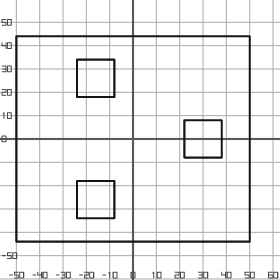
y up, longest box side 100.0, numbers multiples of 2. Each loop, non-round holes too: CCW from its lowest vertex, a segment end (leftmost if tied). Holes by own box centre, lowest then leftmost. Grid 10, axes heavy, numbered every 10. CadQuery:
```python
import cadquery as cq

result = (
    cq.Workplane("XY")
    .moveTo(-50.0, -44.0)
    .lineTo(50.0, -44.0)
    .lineTo(50.0, 44.0)
    .lineTo(-50.0, 44.0)
    .close()
    .moveTo(-24.0, -34.0)
    .lineTo(-8.0, -34.0)
    .lineTo(-8.0, -18.0)
    .lineTo(-24.0, -18.0)
    .close()
    .moveTo(22.0, -8.0)
    .lineTo(38.0, -8.0)
    .lineTo(38.0, 8.0)
    .lineTo(22.0, 8.0)
    .close()
    .moveTo(-24.0, 18.0)
    .lineTo(-8.0, 18.0)
    .lineTo(-8.0, 34.0)
    .lineTo(-24.0, 34.0)
    .close()
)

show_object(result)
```